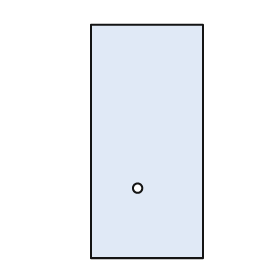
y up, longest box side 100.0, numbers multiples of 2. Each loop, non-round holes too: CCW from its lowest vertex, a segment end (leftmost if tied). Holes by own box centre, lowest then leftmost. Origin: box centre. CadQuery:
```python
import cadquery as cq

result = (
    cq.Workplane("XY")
    .moveTo(-24.0, -50.0)
    .lineTo(24.0, -50.0)
    .lineTo(24.0, 50.0)
    .lineTo(-24.0, 50.0)
    .close()
    .moveTo(-4.0, -20.0)
    .circle(2.0)
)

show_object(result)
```